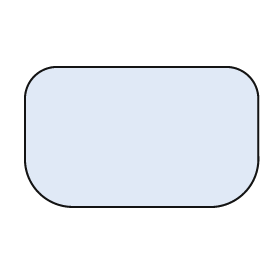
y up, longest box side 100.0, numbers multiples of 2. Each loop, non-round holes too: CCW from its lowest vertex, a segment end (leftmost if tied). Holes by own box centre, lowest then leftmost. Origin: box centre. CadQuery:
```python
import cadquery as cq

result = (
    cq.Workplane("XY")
    .moveTo(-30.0, -30.0)
    .lineTo(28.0, -30.0)
    .threePointArc((44.0, -24.0), (50.0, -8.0))
    .lineTo(50.0, 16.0)
    .threePointArc((46.0, 26.0), (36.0, 30.0))
    .lineTo(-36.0, 30.0)
    .threePointArc((-46.0, 26.0), (-50.0, 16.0))
    .lineTo(-50.0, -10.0)
    .threePointArc((-44.0, -24.0), (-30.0, -30.0))
    .close()
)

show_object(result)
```